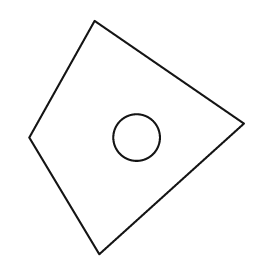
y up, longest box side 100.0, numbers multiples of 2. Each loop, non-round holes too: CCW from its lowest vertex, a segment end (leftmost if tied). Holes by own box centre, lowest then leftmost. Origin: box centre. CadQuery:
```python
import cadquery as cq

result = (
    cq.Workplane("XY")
    .moveTo(-16.0, -50.0)
    .lineTo(46.0, 6.0)
    .lineTo(-18.0, 50.0)
    .lineTo(-46.0, 0.0)
    .close()
    .moveTo(0.0, 0.0)
    .circle(10.0)
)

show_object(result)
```